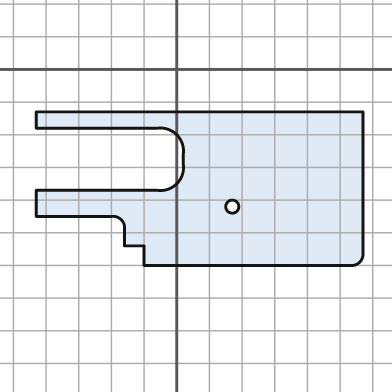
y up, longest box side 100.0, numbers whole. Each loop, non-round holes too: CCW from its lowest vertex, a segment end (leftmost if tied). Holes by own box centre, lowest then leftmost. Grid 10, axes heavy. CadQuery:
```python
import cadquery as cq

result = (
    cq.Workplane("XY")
    .moveTo(-10.0, -60.0)
    .lineTo(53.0, -60.0)
    .threePointArc((56.0, -59.0), (57.0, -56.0))
    .lineTo(57.0, -13.0)
    .lineTo(-43.0, -13.0)
    .lineTo(-43.0, -18.0)
    .lineTo(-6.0, -18.0)
    .threePointArc((0.0, -20.0), (2.0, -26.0))
    .lineTo(2.0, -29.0)
    .threePointArc((0.0, -35.0), (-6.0, -37.0))
    .lineTo(-43.0, -37.0)
    .lineTo(-43.0, -45.0)
    .lineTo(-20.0, -45.0)
    .threePointArc((-17.0, -46.0), (-16.0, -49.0))
    .lineTo(-16.0, -54.0)
    .lineTo(-10.0, -54.0)
    .close()
    .moveTo(17.0, -42.0)
    .circle(2.0)
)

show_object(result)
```